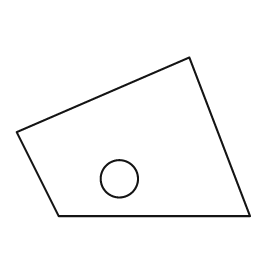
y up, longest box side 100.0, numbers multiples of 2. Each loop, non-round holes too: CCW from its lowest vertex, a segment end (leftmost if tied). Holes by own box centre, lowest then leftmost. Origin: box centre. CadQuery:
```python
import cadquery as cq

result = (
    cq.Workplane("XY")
    .moveTo(-32.0, -34.0)
    .lineTo(50.0, -34.0)
    .lineTo(24.0, 34.0)
    .lineTo(-50.0, 2.0)
    .close()
    .moveTo(-6.0, -18.0)
    .circle(8.0)
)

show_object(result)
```